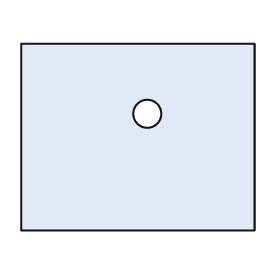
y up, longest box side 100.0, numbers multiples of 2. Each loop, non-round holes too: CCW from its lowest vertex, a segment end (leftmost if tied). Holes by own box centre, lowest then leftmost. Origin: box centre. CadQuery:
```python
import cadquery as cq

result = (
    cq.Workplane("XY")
    .moveTo(-50.0, -40.0)
    .lineTo(50.0, -40.0)
    .lineTo(50.0, 40.0)
    .lineTo(-50.0, 40.0)
    .close()
    .moveTo(4.0, 10.0)
    .circle(6.0)
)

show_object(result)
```